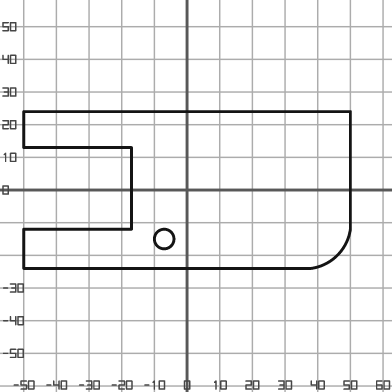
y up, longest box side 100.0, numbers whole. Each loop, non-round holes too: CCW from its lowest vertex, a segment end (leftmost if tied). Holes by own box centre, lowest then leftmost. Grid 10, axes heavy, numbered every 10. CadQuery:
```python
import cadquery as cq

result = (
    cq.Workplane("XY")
    .moveTo(-50.0, -24.0)
    .lineTo(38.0, -24.0)
    .threePointArc((46.0, -20.0), (50.0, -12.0))
    .lineTo(50.0, 24.0)
    .lineTo(-50.0, 24.0)
    .lineTo(-50.0, 13.0)
    .lineTo(-17.0, 13.0)
    .lineTo(-17.0, -12.0)
    .lineTo(-50.0, -12.0)
    .close()
    .moveTo(-7.0, -15.0)
    .circle(3.0)
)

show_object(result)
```